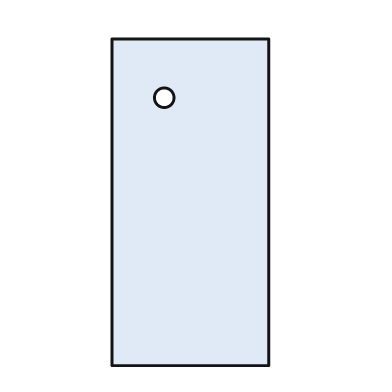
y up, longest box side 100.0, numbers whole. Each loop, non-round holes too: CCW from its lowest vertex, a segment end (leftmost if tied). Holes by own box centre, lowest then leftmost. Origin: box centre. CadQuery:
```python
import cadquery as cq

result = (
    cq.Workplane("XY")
    .moveTo(-24.0, -50.0)
    .lineTo(24.0, -50.0)
    .lineTo(24.0, 50.0)
    .lineTo(-24.0, 50.0)
    .close()
    .moveTo(-8.0, 32.0)
    .circle(3.0)
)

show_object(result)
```